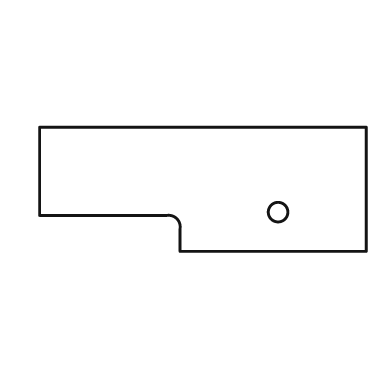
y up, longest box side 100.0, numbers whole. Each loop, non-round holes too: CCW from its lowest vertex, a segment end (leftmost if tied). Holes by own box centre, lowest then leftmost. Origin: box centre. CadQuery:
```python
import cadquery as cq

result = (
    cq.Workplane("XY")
    .moveTo(-7.0, -19.0)
    .lineTo(50.0, -19.0)
    .lineTo(50.0, 19.0)
    .lineTo(-50.0, 19.0)
    .lineTo(-50.0, -8.0)
    .lineTo(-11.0, -8.0)
    .threePointArc((-8.0, -9.0), (-7.0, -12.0))
    .close()
    .moveTo(23.0, -7.0)
    .circle(3.0)
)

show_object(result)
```